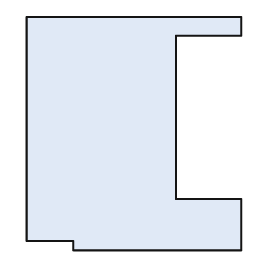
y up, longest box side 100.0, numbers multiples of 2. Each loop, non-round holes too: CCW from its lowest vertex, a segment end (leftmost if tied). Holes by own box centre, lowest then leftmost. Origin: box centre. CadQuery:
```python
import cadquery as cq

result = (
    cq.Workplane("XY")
    .moveTo(-26.0, -50.0)
    .lineTo(46.0, -50.0)
    .lineTo(46.0, -28.0)
    .lineTo(18.0, -28.0)
    .lineTo(18.0, 42.0)
    .lineTo(46.0, 42.0)
    .lineTo(46.0, 50.0)
    .lineTo(-46.0, 50.0)
    .lineTo(-46.0, -46.0)
    .lineTo(-26.0, -46.0)
    .close()
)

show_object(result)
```